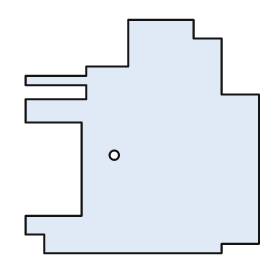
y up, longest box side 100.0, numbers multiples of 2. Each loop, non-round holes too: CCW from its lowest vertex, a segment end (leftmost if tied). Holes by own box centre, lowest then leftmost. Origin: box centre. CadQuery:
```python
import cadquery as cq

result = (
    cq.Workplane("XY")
    .moveTo(-42.0, -50.0)
    .lineTo(34.0, -50.0)
    .lineTo(34.0, -46.0)
    .lineTo(50.0, -46.0)
    .lineTo(50.0, 18.0)
    .lineTo(34.0, 18.0)
    .lineTo(34.0, 42.0)
    .lineTo(22.0, 42.0)
    .lineTo(22.0, 50.0)
    .lineTo(-6.0, 50.0)
    .lineTo(-6.0, 30.0)
    .lineTo(-24.0, 30.0)
    .lineTo(-24.0, 26.0)
    .lineTo(-50.0, 26.0)
    .lineTo(-50.0, 22.0)
    .lineTo(-24.0, 22.0)
    .lineTo(-24.0, 16.0)
    .lineTo(-50.0, 16.0)
    .lineTo(-50.0, 6.0)
    .lineTo(-26.0, 6.0)
    .lineTo(-26.0, -34.0)
    .lineTo(-50.0, -34.0)
    .lineTo(-50.0, -42.0)
    .lineTo(-42.0, -42.0)
    .close()
    .moveTo(-12.0, -8.0)
    .circle(2.0)
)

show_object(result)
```